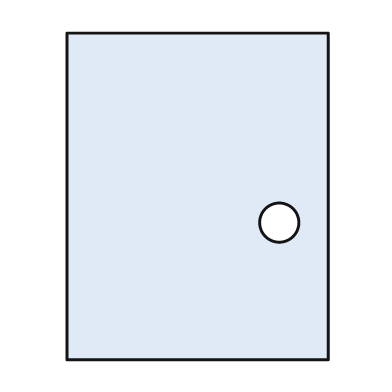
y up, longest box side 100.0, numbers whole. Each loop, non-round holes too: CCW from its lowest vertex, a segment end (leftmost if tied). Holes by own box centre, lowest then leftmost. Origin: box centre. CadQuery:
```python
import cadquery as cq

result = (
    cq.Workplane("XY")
    .moveTo(-40.0, -50.0)
    .lineTo(40.0, -50.0)
    .lineTo(40.0, 50.0)
    .lineTo(-40.0, 50.0)
    .close()
    .moveTo(25.0, -8.0)
    .circle(6.0)
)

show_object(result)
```